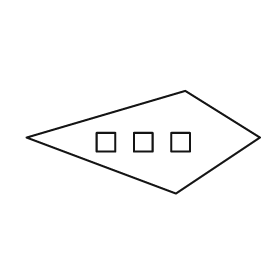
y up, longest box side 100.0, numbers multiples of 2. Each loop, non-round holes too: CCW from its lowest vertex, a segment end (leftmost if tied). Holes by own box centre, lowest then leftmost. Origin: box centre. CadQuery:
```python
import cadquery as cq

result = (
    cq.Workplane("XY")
    .moveTo(14.0, -22.0)
    .lineTo(50.0, 2.0)
    .lineTo(18.0, 22.0)
    .lineTo(-50.0, 2.0)
    .close()
    .moveTo(-20.0, -4.0)
    .lineTo(-12.0, -4.0)
    .lineTo(-12.0, 4.0)
    .lineTo(-20.0, 4.0)
    .close()
    .moveTo(-4.0, -4.0)
    .lineTo(4.0, -4.0)
    .lineTo(4.0, 4.0)
    .lineTo(-4.0, 4.0)
    .close()
    .moveTo(12.0, -4.0)
    .lineTo(20.0, -4.0)
    .lineTo(20.0, 4.0)
    .lineTo(12.0, 4.0)
    .close()
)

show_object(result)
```